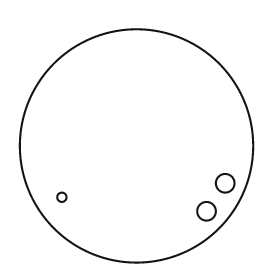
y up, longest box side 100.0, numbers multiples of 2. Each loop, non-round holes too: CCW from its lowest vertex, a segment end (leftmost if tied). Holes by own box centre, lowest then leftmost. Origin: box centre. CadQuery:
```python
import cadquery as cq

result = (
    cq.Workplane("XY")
    .moveTo(0.0, 0.0)
    .circle(50.0)
    .moveTo(30.0, -28.0)
    .circle(4.0)
    .moveTo(-32.0, -22.0)
    .circle(2.0)
    .moveTo(38.0, -16.0)
    .circle(4.0)
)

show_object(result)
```